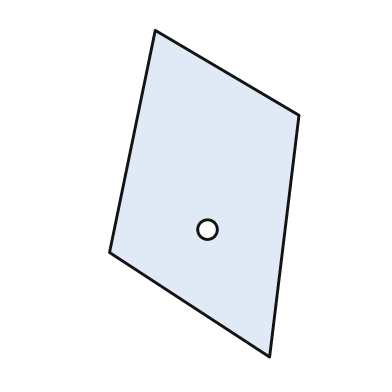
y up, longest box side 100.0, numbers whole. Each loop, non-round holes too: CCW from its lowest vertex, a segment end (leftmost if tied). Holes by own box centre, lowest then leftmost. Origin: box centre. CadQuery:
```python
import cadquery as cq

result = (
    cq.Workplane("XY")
    .moveTo(20.0, -50.0)
    .lineTo(29.0, 24.0)
    .lineTo(-15.0, 50.0)
    .lineTo(-29.0, -18.0)
    .close()
    .moveTo(1.0, -11.0)
    .circle(3.0)
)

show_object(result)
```